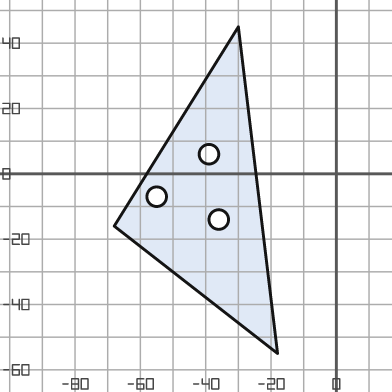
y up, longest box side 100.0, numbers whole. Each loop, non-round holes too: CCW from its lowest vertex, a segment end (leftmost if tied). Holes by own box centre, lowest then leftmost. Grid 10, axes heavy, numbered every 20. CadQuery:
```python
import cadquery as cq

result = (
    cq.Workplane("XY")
    .moveTo(-18.0, -55.0)
    .lineTo(-30.0, 45.0)
    .lineTo(-68.0, -16.0)
    .close()
    .moveTo(-36.0, -14.0)
    .circle(3.0)
    .moveTo(-55.0, -7.0)
    .circle(3.0)
    .moveTo(-39.0, 6.0)
    .circle(3.0)
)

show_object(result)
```